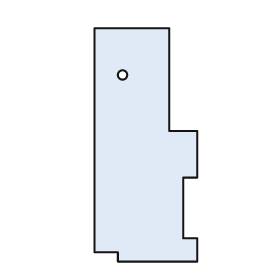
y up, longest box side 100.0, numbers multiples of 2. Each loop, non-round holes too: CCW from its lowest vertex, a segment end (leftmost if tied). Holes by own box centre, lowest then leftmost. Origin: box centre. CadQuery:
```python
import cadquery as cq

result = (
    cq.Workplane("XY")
    .moveTo(-12.0, -50.0)
    .lineTo(22.0, -50.0)
    .lineTo(22.0, -40.0)
    .lineTo(16.0, -40.0)
    .lineTo(16.0, -14.0)
    .lineTo(22.0, -14.0)
    .lineTo(22.0, 6.0)
    .lineTo(10.0, 6.0)
    .lineTo(10.0, 50.0)
    .lineTo(-22.0, 50.0)
    .lineTo(-22.0, -46.0)
    .lineTo(-12.0, -46.0)
    .close()
    .moveTo(-10.0, 30.0)
    .circle(2.0)
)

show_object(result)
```